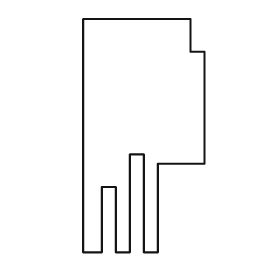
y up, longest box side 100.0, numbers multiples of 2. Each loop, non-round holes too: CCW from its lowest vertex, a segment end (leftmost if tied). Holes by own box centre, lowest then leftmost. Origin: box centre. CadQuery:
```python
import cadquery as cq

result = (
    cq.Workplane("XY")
    .moveTo(-26.0, -50.0)
    .lineTo(-18.0, -50.0)
    .lineTo(-18.0, -22.0)
    .lineTo(-12.0, -22.0)
    .lineTo(-12.0, -50.0)
    .lineTo(-6.0, -50.0)
    .lineTo(-6.0, -8.0)
    .lineTo(0.0, -8.0)
    .lineTo(0.0, -50.0)
    .lineTo(6.0, -50.0)
    .lineTo(6.0, -12.0)
    .lineTo(26.0, -12.0)
    .lineTo(26.0, 36.0)
    .lineTo(20.0, 36.0)
    .lineTo(20.0, 50.0)
    .lineTo(-26.0, 50.0)
    .close()
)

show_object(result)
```